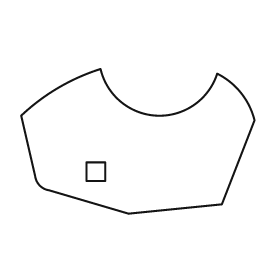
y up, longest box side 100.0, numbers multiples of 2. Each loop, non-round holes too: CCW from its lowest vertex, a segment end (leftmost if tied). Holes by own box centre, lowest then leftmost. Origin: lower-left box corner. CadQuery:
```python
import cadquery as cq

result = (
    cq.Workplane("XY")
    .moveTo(46.0, 0.0)
    .lineTo(86.0, 4.0)
    .lineTo(100.0, 40.0)
    .threePointArc((94.0, 52.0), (84.0, 60.0))
    .threePointArc((58.0, 42.0), (34.0, 62.0))
    .threePointArc((16.0, 54.0), (0.0, 42.0))
    .lineTo(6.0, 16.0)
    .threePointArc((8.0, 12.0), (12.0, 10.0))
    .close()
    .moveTo(28.0, 14.0)
    .lineTo(36.0, 14.0)
    .lineTo(36.0, 22.0)
    .lineTo(28.0, 22.0)
    .close()
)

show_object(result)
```